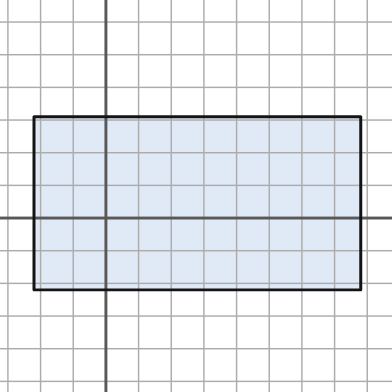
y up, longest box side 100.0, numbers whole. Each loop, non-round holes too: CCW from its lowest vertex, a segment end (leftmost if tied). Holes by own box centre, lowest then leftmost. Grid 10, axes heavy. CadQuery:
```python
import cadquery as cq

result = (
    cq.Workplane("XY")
    .moveTo(-22.0, -22.0)
    .lineTo(78.0, -22.0)
    .lineTo(78.0, 31.0)
    .lineTo(-22.0, 31.0)
    .close()
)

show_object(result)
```